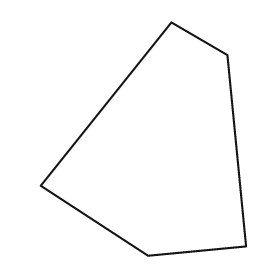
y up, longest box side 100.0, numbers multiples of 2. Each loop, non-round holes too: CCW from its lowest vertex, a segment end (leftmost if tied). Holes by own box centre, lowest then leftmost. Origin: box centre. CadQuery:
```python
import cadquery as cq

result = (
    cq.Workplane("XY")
    .moveTo(2.0, -50.0)
    .lineTo(44.0, -46.0)
    .lineTo(36.0, 36.0)
    .lineTo(12.0, 50.0)
    .lineTo(-44.0, -20.0)
    .close()
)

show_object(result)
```